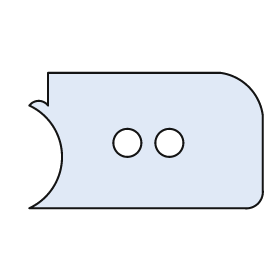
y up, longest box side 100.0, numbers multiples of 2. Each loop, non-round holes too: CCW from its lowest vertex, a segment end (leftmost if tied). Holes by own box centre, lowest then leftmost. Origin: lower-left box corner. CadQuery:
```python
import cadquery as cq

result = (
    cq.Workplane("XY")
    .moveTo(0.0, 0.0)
    .lineTo(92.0, 0.0)
    .threePointArc((98.0, 2.0), (100.0, 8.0))
    .lineTo(100.0, 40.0)
    .threePointArc((94.0, 52.0), (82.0, 58.0))
    .lineTo(8.0, 58.0)
    .lineTo(8.0, 44.0)
    .threePointArc((4.0, 46.0), (0.0, 44.0))
    .threePointArc((14.0, 22.0), (0.0, 0.0))
    .close()
    .moveTo(42.0, 28.0)
    .circle(6.0)
    .moveTo(60.0, 28.0)
    .circle(6.0)
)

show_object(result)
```